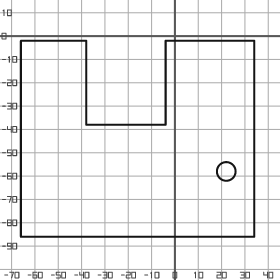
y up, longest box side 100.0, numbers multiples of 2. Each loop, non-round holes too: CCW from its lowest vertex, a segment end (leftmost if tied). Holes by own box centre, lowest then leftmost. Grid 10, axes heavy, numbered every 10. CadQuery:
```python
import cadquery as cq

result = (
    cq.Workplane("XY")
    .moveTo(-66.0, -86.0)
    .lineTo(34.0, -86.0)
    .lineTo(34.0, -2.0)
    .lineTo(-4.0, -2.0)
    .lineTo(-4.0, -38.0)
    .lineTo(-38.0, -38.0)
    .lineTo(-38.0, -2.0)
    .lineTo(-66.0, -2.0)
    .close()
    .moveTo(22.0, -58.0)
    .circle(4.0)
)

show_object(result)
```